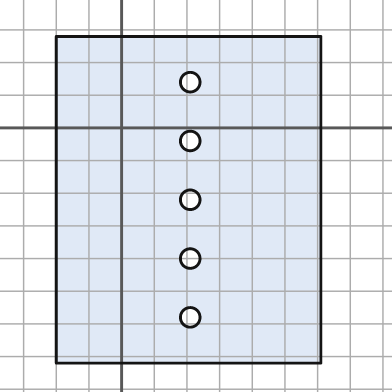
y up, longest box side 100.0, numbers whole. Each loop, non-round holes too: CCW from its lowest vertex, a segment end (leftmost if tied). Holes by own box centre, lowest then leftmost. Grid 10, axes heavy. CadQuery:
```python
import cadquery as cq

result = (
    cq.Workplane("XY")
    .moveTo(-20.0, -72.0)
    .lineTo(61.0, -72.0)
    .lineTo(61.0, 28.0)
    .lineTo(-20.0, 28.0)
    .close()
    .moveTo(21.0, -58.0)
    .circle(3.0)
    .moveTo(21.0, -40.0)
    .circle(3.0)
    .moveTo(21.0, -22.0)
    .circle(3.0)
    .moveTo(21.0, -4.0)
    .circle(3.0)
    .moveTo(21.0, 14.0)
    .circle(3.0)
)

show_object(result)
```